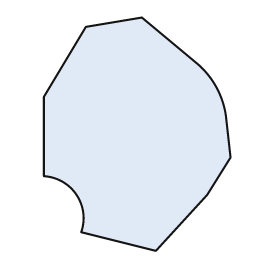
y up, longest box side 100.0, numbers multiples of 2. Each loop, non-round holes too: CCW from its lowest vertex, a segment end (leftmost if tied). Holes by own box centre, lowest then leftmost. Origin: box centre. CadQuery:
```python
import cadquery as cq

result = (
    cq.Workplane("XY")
    .moveTo(8.0, -50.0)
    .lineTo(30.0, -26.0)
    .lineTo(40.0, -10.0)
    .lineTo(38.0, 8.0)
    .threePointArc((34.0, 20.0), (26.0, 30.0))
    .lineTo(2.0, 50.0)
    .lineTo(-22.0, 46.0)
    .lineTo(-40.0, 16.0)
    .lineTo(-40.0, -18.0)
    .threePointArc((-26.0, -26.0), (-24.0, -42.0))
    .close()
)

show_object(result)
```